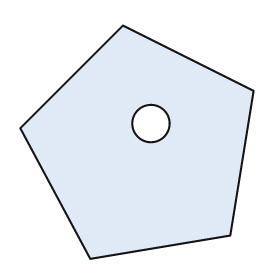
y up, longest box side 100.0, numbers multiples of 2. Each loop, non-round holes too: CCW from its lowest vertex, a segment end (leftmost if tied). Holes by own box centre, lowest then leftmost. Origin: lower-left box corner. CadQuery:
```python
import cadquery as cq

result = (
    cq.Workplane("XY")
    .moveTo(30.0, 0.0)
    .lineTo(90.0, 10.0)
    .lineTo(100.0, 72.0)
    .lineTo(44.0, 100.0)
    .lineTo(0.0, 56.0)
    .close()
    .moveTo(56.0, 58.0)
    .circle(8.0)
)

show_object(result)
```